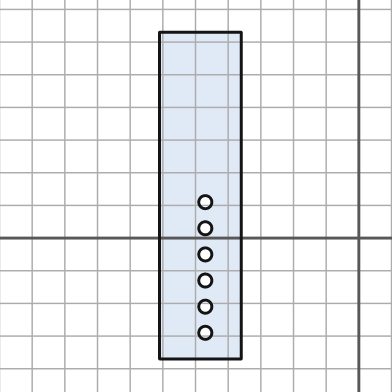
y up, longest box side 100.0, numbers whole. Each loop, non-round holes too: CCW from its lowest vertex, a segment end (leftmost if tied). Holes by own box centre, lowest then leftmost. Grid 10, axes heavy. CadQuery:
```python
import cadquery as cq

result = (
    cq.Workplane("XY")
    .moveTo(-61.0, -37.0)
    .lineTo(-36.0, -37.0)
    .lineTo(-36.0, 63.0)
    .lineTo(-61.0, 63.0)
    .close()
    .moveTo(-47.0, -29.0)
    .circle(2.0)
    .moveTo(-47.0, -21.0)
    .circle(2.0)
    .moveTo(-47.0, -13.0)
    .circle(2.0)
    .moveTo(-47.0, -5.0)
    .circle(2.0)
    .moveTo(-47.0, 3.0)
    .circle(2.0)
    .moveTo(-47.0, 11.0)
    .circle(2.0)
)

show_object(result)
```